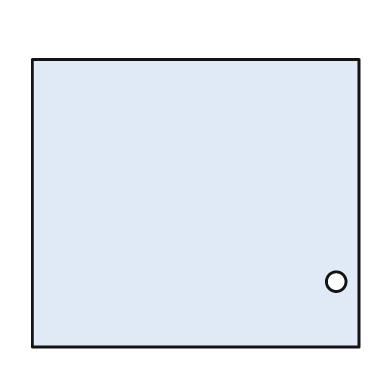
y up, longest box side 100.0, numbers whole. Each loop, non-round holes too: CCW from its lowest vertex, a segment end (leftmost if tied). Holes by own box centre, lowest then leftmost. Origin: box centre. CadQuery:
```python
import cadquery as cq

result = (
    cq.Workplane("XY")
    .moveTo(-50.0, -44.0)
    .lineTo(50.0, -44.0)
    .lineTo(50.0, 44.0)
    .lineTo(-50.0, 44.0)
    .close()
    .moveTo(43.0, -24.0)
    .circle(3.0)
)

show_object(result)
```